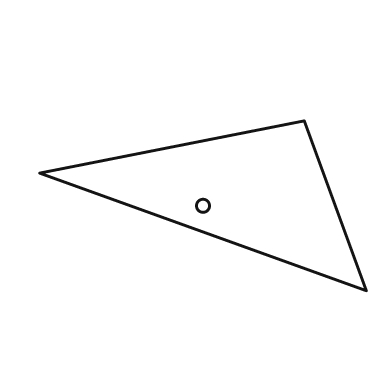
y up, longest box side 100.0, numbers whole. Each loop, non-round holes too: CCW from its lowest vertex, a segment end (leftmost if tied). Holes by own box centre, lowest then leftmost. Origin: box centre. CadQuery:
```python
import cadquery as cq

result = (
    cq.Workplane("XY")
    .moveTo(50.0, -26.0)
    .lineTo(31.0, 26.0)
    .lineTo(-50.0, 10.0)
    .close()
    .moveTo(0.0, 0.0)
    .circle(2.0)
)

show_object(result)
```